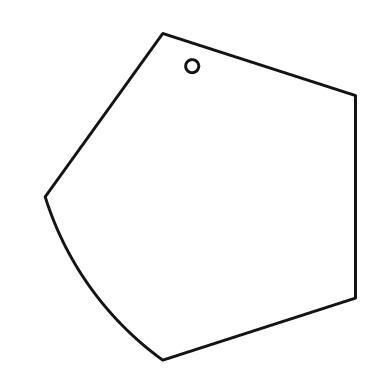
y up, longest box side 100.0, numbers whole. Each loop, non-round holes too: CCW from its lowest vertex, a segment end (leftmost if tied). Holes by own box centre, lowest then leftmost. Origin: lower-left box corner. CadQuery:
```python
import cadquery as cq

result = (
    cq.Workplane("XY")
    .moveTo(36.0, 0.0)
    .lineTo(95.0, 19.0)
    .lineTo(95.0, 81.0)
    .lineTo(36.0, 100.0)
    .lineTo(0.0, 50.0)
    .threePointArc((14.0, 22.0), (36.0, 0.0))
    .close()
    .moveTo(45.0, 90.0)
    .circle(2.0)
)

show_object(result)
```